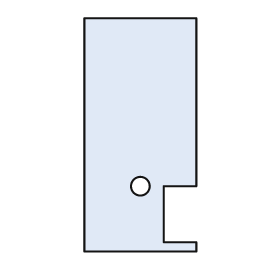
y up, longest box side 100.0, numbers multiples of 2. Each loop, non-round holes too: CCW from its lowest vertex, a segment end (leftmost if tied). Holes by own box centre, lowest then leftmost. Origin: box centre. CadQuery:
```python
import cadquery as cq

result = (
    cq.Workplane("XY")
    .moveTo(-24.0, -50.0)
    .lineTo(24.0, -50.0)
    .lineTo(24.0, -46.0)
    .lineTo(10.0, -46.0)
    .lineTo(10.0, -22.0)
    .lineTo(24.0, -22.0)
    .lineTo(24.0, 50.0)
    .lineTo(-24.0, 50.0)
    .close()
    .moveTo(0.0, -22.0)
    .circle(4.0)
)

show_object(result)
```